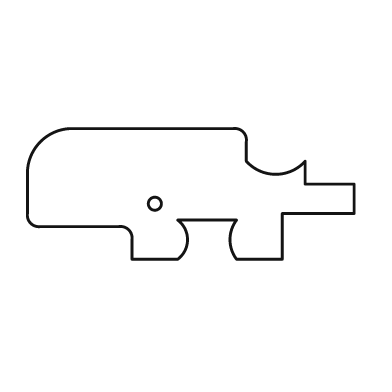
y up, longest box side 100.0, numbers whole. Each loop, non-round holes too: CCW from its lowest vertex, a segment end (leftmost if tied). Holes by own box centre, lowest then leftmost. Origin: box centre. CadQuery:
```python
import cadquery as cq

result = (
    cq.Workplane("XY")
    .moveTo(-18.0, -20.0)
    .lineTo(-4.0, -20.0)
    .threePointArc((-1.0, -14.0), (-4.0, -8.0))
    .lineTo(14.0, -8.0)
    .threePointArc((12.0, -14.0), (14.0, -20.0))
    .lineTo(28.0, -20.0)
    .lineTo(28.0, -6.0)
    .lineTo(50.0, -6.0)
    .lineTo(50.0, 3.0)
    .lineTo(35.0, 3.0)
    .lineTo(35.0, 10.0)
    .threePointArc((26.0, 6.0), (17.0, 10.0))
    .lineTo(17.0, 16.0)
    .threePointArc((16.0, 19.0), (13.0, 20.0))
    .lineTo(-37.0, 20.0)
    .threePointArc((-46.0, 16.0), (-50.0, 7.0))
    .lineTo(-50.0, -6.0)
    .threePointArc((-49.0, -9.0), (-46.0, -10.0))
    .lineTo(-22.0, -10.0)
    .threePointArc((-19.0, -11.0), (-18.0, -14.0))
    .close()
    .moveTo(-11.0, -3.0)
    .circle(2.0)
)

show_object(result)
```